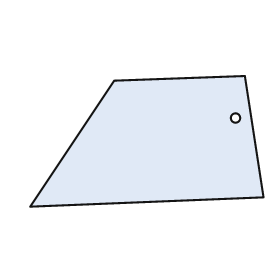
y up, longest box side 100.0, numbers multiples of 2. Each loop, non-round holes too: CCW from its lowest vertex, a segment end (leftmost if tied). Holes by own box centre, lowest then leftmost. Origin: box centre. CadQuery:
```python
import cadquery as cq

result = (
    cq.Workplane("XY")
    .moveTo(-50.0, -28.0)
    .lineTo(50.0, -24.0)
    .lineTo(42.0, 28.0)
    .lineTo(-14.0, 26.0)
    .close()
    .moveTo(38.0, 10.0)
    .circle(2.0)
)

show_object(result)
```